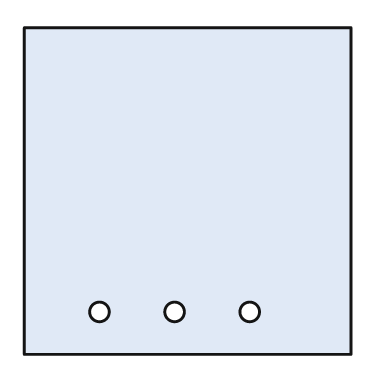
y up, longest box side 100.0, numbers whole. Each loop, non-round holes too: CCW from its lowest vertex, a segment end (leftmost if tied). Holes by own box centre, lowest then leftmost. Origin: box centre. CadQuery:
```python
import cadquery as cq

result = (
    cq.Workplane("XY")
    .moveTo(-50.0, -50.0)
    .lineTo(50.0, -50.0)
    .lineTo(50.0, 50.0)
    .lineTo(-50.0, 50.0)
    .close()
    .moveTo(-27.0, -37.0)
    .circle(3.0)
    .moveTo(-4.0, -37.0)
    .circle(3.0)
    .moveTo(19.0, -37.0)
    .circle(3.0)
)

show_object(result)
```